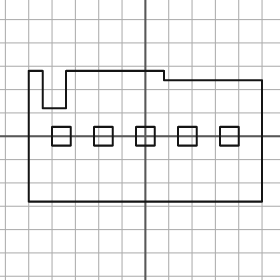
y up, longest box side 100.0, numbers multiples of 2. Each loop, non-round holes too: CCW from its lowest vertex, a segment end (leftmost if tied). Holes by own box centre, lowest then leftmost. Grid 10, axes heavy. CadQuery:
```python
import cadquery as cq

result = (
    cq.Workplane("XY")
    .moveTo(-50.0, -28.0)
    .lineTo(50.0, -28.0)
    .lineTo(50.0, 24.0)
    .lineTo(8.0, 24.0)
    .lineTo(8.0, 28.0)
    .lineTo(-34.0, 28.0)
    .lineTo(-34.0, 12.0)
    .lineTo(-44.0, 12.0)
    .lineTo(-44.0, 28.0)
    .lineTo(-50.0, 28.0)
    .close()
    .moveTo(-40.0, -4.0)
    .lineTo(-32.0, -4.0)
    .lineTo(-32.0, 4.0)
    .lineTo(-40.0, 4.0)
    .close()
    .moveTo(-22.0, -4.0)
    .lineTo(-14.0, -4.0)
    .lineTo(-14.0, 4.0)
    .lineTo(-22.0, 4.0)
    .close()
    .moveTo(-4.0, -4.0)
    .lineTo(4.0, -4.0)
    .lineTo(4.0, 4.0)
    .lineTo(-4.0, 4.0)
    .close()
    .moveTo(14.0, -4.0)
    .lineTo(22.0, -4.0)
    .lineTo(22.0, 4.0)
    .lineTo(14.0, 4.0)
    .close()
    .moveTo(32.0, -4.0)
    .lineTo(40.0, -4.0)
    .lineTo(40.0, 4.0)
    .lineTo(32.0, 4.0)
    .close()
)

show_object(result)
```